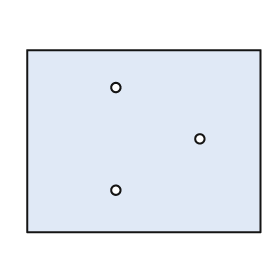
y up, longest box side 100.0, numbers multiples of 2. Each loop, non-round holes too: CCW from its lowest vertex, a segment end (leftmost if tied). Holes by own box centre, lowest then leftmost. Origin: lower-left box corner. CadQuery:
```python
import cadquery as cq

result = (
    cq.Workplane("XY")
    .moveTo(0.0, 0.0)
    .lineTo(100.0, 0.0)
    .lineTo(100.0, 78.0)
    .lineTo(0.0, 78.0)
    .close()
    .moveTo(38.0, 18.0)
    .circle(2.0)
    .moveTo(74.0, 40.0)
    .circle(2.0)
    .moveTo(38.0, 62.0)
    .circle(2.0)
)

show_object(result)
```